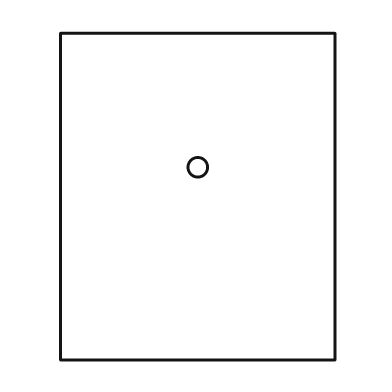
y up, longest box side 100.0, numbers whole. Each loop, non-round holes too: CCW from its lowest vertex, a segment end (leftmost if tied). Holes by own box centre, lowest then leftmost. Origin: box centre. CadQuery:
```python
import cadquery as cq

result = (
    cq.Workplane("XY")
    .moveTo(-42.0, -50.0)
    .lineTo(42.0, -50.0)
    .lineTo(42.0, 50.0)
    .lineTo(-42.0, 50.0)
    .close()
    .moveTo(0.0, 9.0)
    .circle(3.0)
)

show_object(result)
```